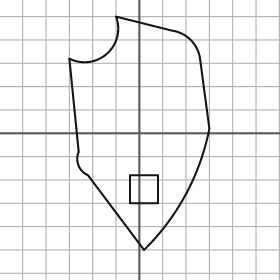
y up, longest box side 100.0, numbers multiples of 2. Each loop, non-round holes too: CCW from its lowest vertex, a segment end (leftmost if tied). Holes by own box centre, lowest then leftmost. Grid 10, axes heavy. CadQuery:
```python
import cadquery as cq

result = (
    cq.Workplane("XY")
    .moveTo(2.0, -50.0)
    .threePointArc((20.0, -26.0), (30.0, 2.0))
    .lineTo(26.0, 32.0)
    .threePointArc((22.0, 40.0), (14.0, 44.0))
    .lineTo(-10.0, 50.0)
    .threePointArc((-14.0, 34.0), (-30.0, 32.0))
    .lineTo(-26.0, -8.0)
    .threePointArc((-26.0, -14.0), (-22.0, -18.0))
    .close()
    .moveTo(-4.0, -30.0)
    .lineTo(8.0, -30.0)
    .lineTo(8.0, -18.0)
    .lineTo(-4.0, -18.0)
    .close()
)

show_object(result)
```